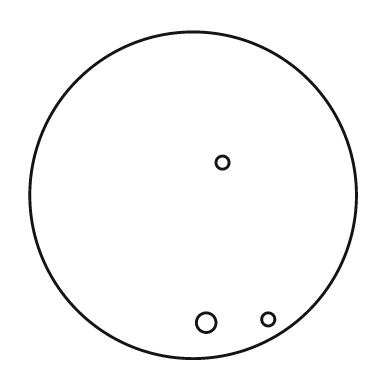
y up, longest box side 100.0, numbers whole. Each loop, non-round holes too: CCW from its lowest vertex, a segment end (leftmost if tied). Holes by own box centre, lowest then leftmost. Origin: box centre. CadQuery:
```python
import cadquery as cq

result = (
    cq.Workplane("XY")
    .moveTo(0.0, 0.0)
    .circle(50.0)
    .moveTo(4.0, -39.0)
    .circle(3.0)
    .moveTo(23.0, -38.0)
    .circle(2.0)
    .moveTo(9.0, 10.0)
    .circle(2.0)
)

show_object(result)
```